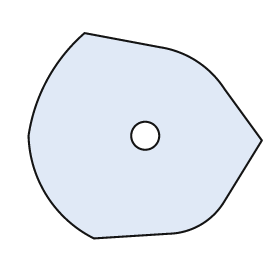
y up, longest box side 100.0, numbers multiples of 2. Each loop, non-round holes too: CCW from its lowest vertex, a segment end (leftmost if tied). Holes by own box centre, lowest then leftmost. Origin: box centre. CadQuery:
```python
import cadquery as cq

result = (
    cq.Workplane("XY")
    .moveTo(-22.0, -44.0)
    .lineTo(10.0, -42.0)
    .threePointArc((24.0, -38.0), (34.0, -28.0))
    .lineTo(50.0, -2.0)
    .lineTo(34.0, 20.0)
    .threePointArc((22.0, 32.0), (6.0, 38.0))
    .lineTo(-26.0, 44.0)
    .threePointArc((-42.0, 24.0), (-50.0, 0.0))
    .threePointArc((-42.0, -26.0), (-22.0, -44.0))
    .close()
    .moveTo(0.0, 0.0)
    .circle(6.0)
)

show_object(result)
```